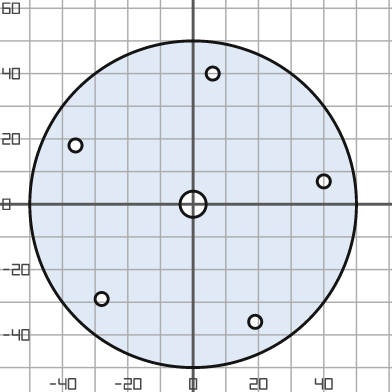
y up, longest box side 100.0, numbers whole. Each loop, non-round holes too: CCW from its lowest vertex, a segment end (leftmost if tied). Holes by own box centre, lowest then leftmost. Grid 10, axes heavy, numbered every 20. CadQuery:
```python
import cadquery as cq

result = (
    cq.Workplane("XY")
    .moveTo(0.0, 0.0)
    .circle(50.0)
    .moveTo(19.0, -36.0)
    .circle(2.0)
    .moveTo(-28.0, -29.0)
    .circle(2.0)
    .moveTo(0.0, 0.0)
    .circle(4.0)
    .moveTo(40.0, 7.0)
    .circle(2.0)
    .moveTo(-36.0, 18.0)
    .circle(2.0)
    .moveTo(6.0, 40.0)
    .circle(2.0)
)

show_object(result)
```